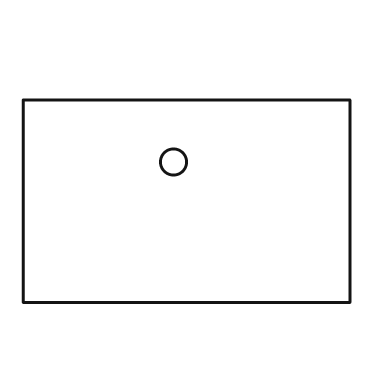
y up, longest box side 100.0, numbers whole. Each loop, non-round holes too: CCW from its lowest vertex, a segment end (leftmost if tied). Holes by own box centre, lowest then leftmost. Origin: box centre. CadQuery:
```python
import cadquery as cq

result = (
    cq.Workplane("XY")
    .moveTo(-50.0, -31.0)
    .lineTo(50.0, -31.0)
    .lineTo(50.0, 31.0)
    .lineTo(-50.0, 31.0)
    .close()
    .moveTo(-4.0, 12.0)
    .circle(4.0)
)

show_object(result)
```